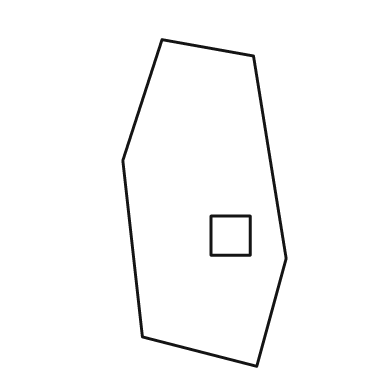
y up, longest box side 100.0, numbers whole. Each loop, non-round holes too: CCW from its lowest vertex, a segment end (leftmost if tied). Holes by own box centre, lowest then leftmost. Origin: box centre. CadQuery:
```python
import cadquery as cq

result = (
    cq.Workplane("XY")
    .moveTo(16.0, -50.0)
    .lineTo(25.0, -17.0)
    .lineTo(15.0, 45.0)
    .lineTo(-13.0, 50.0)
    .lineTo(-25.0, 13.0)
    .lineTo(-19.0, -41.0)
    .close()
    .moveTo(2.0, -16.0)
    .lineTo(14.0, -16.0)
    .lineTo(14.0, -4.0)
    .lineTo(2.0, -4.0)
    .close()
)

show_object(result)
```